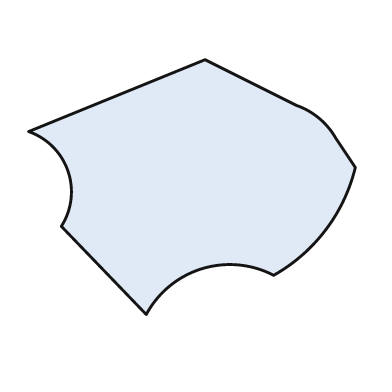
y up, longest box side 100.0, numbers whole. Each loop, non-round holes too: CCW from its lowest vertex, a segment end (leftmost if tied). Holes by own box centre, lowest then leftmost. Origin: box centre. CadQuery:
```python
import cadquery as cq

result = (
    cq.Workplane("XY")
    .moveTo(-14.0, -39.0)
    .threePointArc((3.0, -25.0), (25.0, -27.0))
    .threePointArc((41.0, -13.0), (50.0, 6.0))
    .lineTo(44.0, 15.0)
    .threePointArc((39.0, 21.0), (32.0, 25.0))
    .lineTo(4.0, 39.0)
    .lineTo(-50.0, 17.0)
    .threePointArc((-38.0, 5.0), (-40.0, -12.0))
    .close()
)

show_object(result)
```